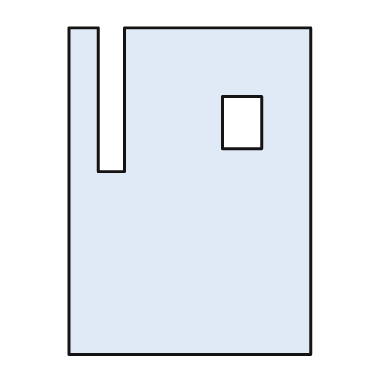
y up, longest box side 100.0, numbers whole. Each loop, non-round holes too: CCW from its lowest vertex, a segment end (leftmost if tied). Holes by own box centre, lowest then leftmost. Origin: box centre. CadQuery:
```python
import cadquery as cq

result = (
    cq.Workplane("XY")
    .moveTo(-37.0, -50.0)
    .lineTo(37.0, -50.0)
    .lineTo(37.0, 50.0)
    .lineTo(-20.0, 50.0)
    .lineTo(-20.0, 6.0)
    .lineTo(-28.0, 6.0)
    .lineTo(-28.0, 50.0)
    .lineTo(-37.0, 50.0)
    .close()
    .moveTo(10.0, 13.0)
    .lineTo(22.0, 13.0)
    .lineTo(22.0, 29.0)
    .lineTo(10.0, 29.0)
    .close()
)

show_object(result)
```